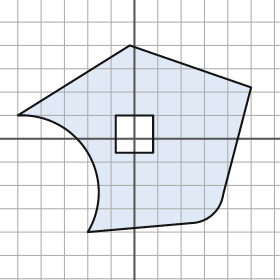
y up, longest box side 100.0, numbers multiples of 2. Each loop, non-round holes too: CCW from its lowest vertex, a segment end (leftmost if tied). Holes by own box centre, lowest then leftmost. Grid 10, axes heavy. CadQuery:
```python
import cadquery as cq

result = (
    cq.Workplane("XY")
    .moveTo(-20.0, -40.0)
    .lineTo(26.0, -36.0)
    .threePointArc((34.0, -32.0), (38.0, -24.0))
    .lineTo(50.0, 22.0)
    .lineTo(-2.0, 40.0)
    .lineTo(-50.0, 10.0)
    .threePointArc((-20.0, -6.0), (-20.0, -40.0))
    .close()
    .moveTo(-8.0, -6.0)
    .lineTo(8.0, -6.0)
    .lineTo(8.0, 10.0)
    .lineTo(-8.0, 10.0)
    .close()
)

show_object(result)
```